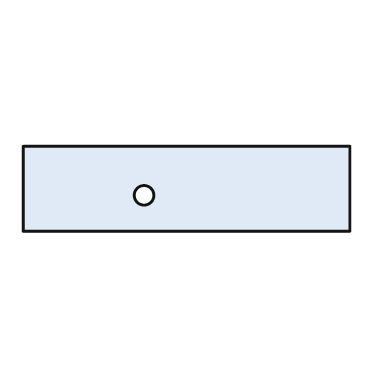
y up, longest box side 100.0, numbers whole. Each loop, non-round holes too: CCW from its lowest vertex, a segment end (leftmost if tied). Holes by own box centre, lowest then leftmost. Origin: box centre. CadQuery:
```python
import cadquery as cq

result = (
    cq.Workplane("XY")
    .moveTo(-50.0, -13.0)
    .lineTo(50.0, -13.0)
    .lineTo(50.0, 13.0)
    .lineTo(-50.0, 13.0)
    .close()
    .moveTo(-13.0, -2.0)
    .circle(3.0)
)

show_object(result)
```